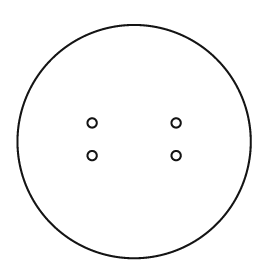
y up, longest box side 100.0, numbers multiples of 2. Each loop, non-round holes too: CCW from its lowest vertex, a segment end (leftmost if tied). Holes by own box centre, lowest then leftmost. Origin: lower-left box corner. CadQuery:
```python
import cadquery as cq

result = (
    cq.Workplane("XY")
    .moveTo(50.0, 50.0)
    .circle(50.0)
    .moveTo(32.0, 44.0)
    .circle(2.0)
    .moveTo(68.0, 44.0)
    .circle(2.0)
    .moveTo(32.0, 58.0)
    .circle(2.0)
    .moveTo(68.0, 58.0)
    .circle(2.0)
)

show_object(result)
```